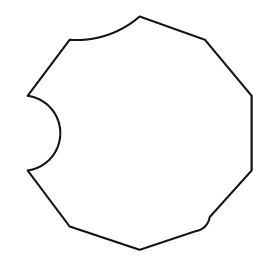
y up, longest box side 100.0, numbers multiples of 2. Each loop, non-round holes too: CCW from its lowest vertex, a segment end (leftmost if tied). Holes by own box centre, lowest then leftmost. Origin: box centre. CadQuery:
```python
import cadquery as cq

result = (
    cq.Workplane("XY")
    .moveTo(0.0, -50.0)
    .lineTo(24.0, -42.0)
    .threePointArc((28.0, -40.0), (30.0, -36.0))
    .lineTo(48.0, -16.0)
    .lineTo(48.0, 16.0)
    .lineTo(28.0, 40.0)
    .lineTo(0.0, 50.0)
    .threePointArc((-14.0, 42.0), (-30.0, 40.0))
    .lineTo(-48.0, 16.0)
    .threePointArc((-34.0, 0.0), (-48.0, -16.0))
    .lineTo(-30.0, -40.0)
    .close()
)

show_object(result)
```